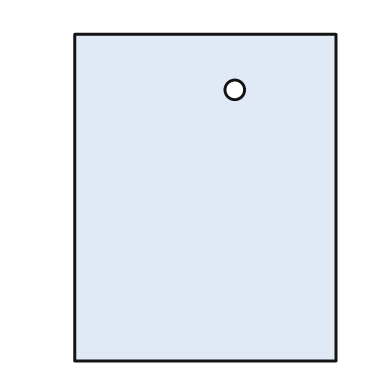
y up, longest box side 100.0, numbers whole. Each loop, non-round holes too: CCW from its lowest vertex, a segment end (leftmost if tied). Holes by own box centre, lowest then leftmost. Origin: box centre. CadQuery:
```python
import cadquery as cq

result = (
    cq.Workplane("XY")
    .moveTo(-40.0, -50.0)
    .lineTo(40.0, -50.0)
    .lineTo(40.0, 50.0)
    .lineTo(-40.0, 50.0)
    .close()
    .moveTo(9.0, 33.0)
    .circle(3.0)
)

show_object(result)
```